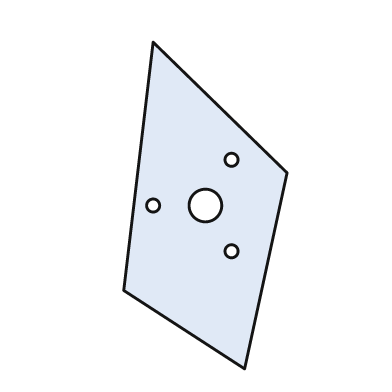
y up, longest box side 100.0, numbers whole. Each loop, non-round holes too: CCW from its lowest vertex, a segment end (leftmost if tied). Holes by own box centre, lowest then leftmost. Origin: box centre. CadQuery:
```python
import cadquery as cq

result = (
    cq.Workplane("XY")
    .moveTo(12.0, -50.0)
    .lineTo(25.0, 10.0)
    .lineTo(-16.0, 50.0)
    .lineTo(-25.0, -26.0)
    .close()
    .moveTo(8.0, -14.0)
    .circle(2.0)
    .moveTo(-16.0, 0.0)
    .circle(2.0)
    .moveTo(0.0, 0.0)
    .circle(5.0)
    .moveTo(8.0, 14.0)
    .circle(2.0)
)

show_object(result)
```